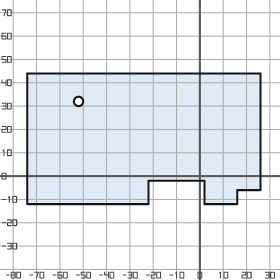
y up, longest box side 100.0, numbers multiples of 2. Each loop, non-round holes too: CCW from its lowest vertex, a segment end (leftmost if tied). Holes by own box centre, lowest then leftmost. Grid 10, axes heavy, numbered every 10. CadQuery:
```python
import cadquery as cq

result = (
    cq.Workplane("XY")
    .moveTo(-74.0, -12.0)
    .lineTo(-22.0, -12.0)
    .lineTo(-22.0, -2.0)
    .lineTo(2.0, -2.0)
    .lineTo(2.0, -12.0)
    .lineTo(16.0, -12.0)
    .lineTo(16.0, -6.0)
    .lineTo(26.0, -6.0)
    .lineTo(26.0, 44.0)
    .lineTo(-74.0, 44.0)
    .close()
    .moveTo(-52.0, 32.0)
    .circle(2.0)
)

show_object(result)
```